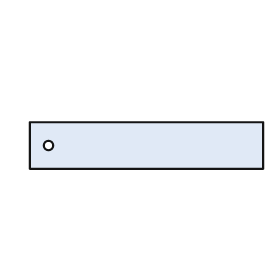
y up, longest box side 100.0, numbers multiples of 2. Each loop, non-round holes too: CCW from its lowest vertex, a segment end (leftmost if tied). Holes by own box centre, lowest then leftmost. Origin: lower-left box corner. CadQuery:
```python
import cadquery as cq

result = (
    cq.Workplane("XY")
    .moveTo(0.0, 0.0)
    .lineTo(100.0, 0.0)
    .lineTo(100.0, 20.0)
    .lineTo(0.0, 20.0)
    .close()
    .moveTo(8.0, 10.0)
    .circle(2.0)
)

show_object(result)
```